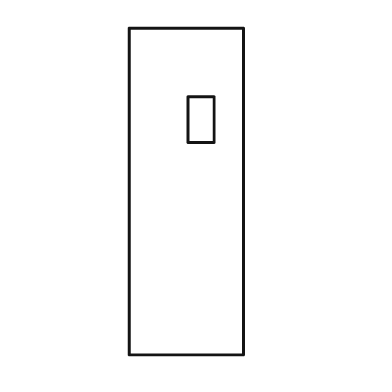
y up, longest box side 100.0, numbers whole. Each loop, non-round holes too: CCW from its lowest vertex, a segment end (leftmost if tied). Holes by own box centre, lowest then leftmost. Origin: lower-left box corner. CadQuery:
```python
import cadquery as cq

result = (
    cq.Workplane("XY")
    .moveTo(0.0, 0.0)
    .lineTo(35.0, 0.0)
    .lineTo(35.0, 100.0)
    .lineTo(0.0, 100.0)
    .close()
    .moveTo(18.0, 65.0)
    .lineTo(26.0, 65.0)
    .lineTo(26.0, 79.0)
    .lineTo(18.0, 79.0)
    .close()
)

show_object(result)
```